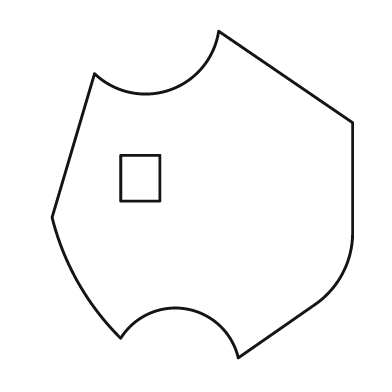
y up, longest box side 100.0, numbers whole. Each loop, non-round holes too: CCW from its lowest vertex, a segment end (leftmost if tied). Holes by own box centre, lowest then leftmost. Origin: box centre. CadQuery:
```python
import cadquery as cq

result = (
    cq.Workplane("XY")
    .moveTo(11.0, -50.0)
    .lineTo(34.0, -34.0)
    .threePointArc((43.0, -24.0), (46.0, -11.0))
    .lineTo(46.0, 22.0)
    .lineTo(5.0, 50.0)
    .threePointArc((-10.0, 32.0), (-33.0, 37.0))
    .lineTo(-46.0, -7.0)
    .threePointArc((-38.0, -27.0), (-25.0, -44.0))
    .threePointArc((-5.0, -35.0), (11.0, -50.0))
    .close()
    .moveTo(-25.0, -2.0)
    .lineTo(-13.0, -2.0)
    .lineTo(-13.0, 12.0)
    .lineTo(-25.0, 12.0)
    .close()
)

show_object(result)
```